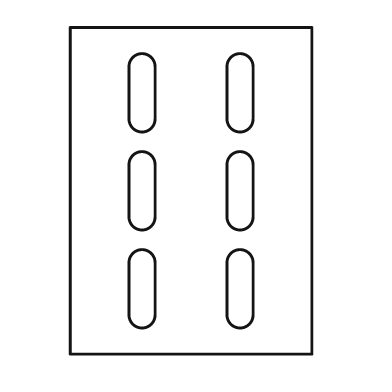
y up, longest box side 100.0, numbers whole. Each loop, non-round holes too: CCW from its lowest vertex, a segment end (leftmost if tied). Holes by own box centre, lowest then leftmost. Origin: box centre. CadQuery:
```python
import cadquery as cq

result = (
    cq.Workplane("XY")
    .moveTo(-37.0, -50.0)
    .lineTo(37.0, -50.0)
    .lineTo(37.0, 50.0)
    .lineTo(-37.0, 50.0)
    .close()
    .moveTo(-19.0, -38.0)
    .threePointArc((-15.0, -42.0), (-11.0, -38.0))
    .lineTo(-11.0, -22.0)
    .threePointArc((-15.0, -18.0), (-19.0, -22.0))
    .close()
    .moveTo(11.0, -38.0)
    .threePointArc((15.0, -42.0), (19.0, -38.0))
    .lineTo(19.0, -22.0)
    .threePointArc((15.0, -18.0), (11.0, -22.0))
    .close()
    .moveTo(-19.0, -8.0)
    .threePointArc((-15.0, -12.0), (-11.0, -8.0))
    .lineTo(-11.0, 8.0)
    .threePointArc((-15.0, 12.0), (-19.0, 8.0))
    .close()
    .moveTo(11.0, -8.0)
    .threePointArc((15.0, -12.0), (19.0, -8.0))
    .lineTo(19.0, 8.0)
    .threePointArc((15.0, 12.0), (11.0, 8.0))
    .close()
    .moveTo(-19.0, 22.0)
    .threePointArc((-15.0, 18.0), (-11.0, 22.0))
    .lineTo(-11.0, 38.0)
    .threePointArc((-15.0, 42.0), (-19.0, 38.0))
    .close()
    .moveTo(11.0, 22.0)
    .threePointArc((15.0, 18.0), (19.0, 22.0))
    .lineTo(19.0, 38.0)
    .threePointArc((15.0, 42.0), (11.0, 38.0))
    .close()
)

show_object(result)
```